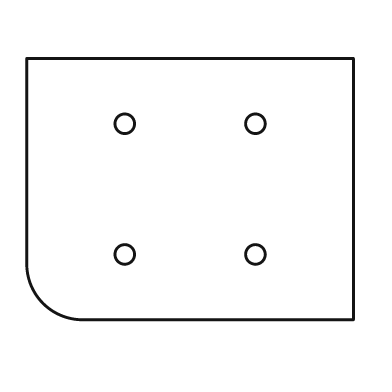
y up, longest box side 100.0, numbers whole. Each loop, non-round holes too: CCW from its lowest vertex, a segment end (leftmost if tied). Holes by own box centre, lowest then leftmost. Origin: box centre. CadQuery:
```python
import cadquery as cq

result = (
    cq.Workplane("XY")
    .moveTo(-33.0, -40.0)
    .lineTo(50.0, -40.0)
    .lineTo(50.0, 40.0)
    .lineTo(-50.0, 40.0)
    .lineTo(-50.0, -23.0)
    .threePointArc((-45.0, -35.0), (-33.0, -40.0))
    .close()
    .moveTo(-20.0, -20.0)
    .circle(3.0)
    .moveTo(20.0, -20.0)
    .circle(3.0)
    .moveTo(-20.0, 20.0)
    .circle(3.0)
    .moveTo(20.0, 20.0)
    .circle(3.0)
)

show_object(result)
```